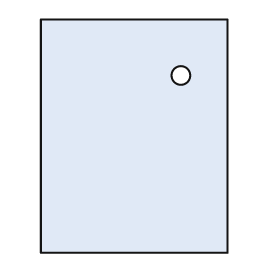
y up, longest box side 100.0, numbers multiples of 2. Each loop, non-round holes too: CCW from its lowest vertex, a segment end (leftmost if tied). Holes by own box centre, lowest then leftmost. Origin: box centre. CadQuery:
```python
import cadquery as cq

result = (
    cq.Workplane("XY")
    .moveTo(-40.0, -50.0)
    .lineTo(40.0, -50.0)
    .lineTo(40.0, 50.0)
    .lineTo(-40.0, 50.0)
    .close()
    .moveTo(20.0, 26.0)
    .circle(4.0)
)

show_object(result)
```